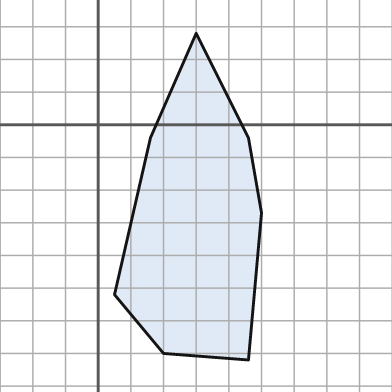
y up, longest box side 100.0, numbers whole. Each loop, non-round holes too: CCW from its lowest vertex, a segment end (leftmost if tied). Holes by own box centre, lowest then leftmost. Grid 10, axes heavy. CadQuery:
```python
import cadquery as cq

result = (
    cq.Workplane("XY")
    .moveTo(46.0, -72.0)
    .lineTo(50.0, -27.0)
    .lineTo(46.0, -4.0)
    .lineTo(30.0, 28.0)
    .lineTo(16.0, -4.0)
    .lineTo(5.0, -52.0)
    .lineTo(20.0, -70.0)
    .close()
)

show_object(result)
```